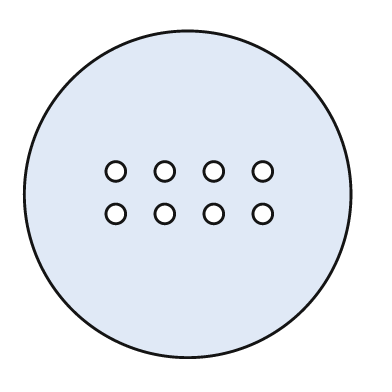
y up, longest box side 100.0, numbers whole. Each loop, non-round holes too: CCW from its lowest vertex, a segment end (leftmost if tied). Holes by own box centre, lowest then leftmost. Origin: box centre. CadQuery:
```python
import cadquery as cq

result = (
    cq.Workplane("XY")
    .moveTo(0.0, 0.0)
    .circle(50.0)
    .moveTo(-22.0, -6.0)
    .circle(3.0)
    .moveTo(-7.0, -6.0)
    .circle(3.0)
    .moveTo(8.0, -6.0)
    .circle(3.0)
    .moveTo(23.0, -6.0)
    .circle(3.0)
    .moveTo(-22.0, 7.0)
    .circle(3.0)
    .moveTo(-7.0, 7.0)
    .circle(3.0)
    .moveTo(8.0, 7.0)
    .circle(3.0)
    .moveTo(23.0, 7.0)
    .circle(3.0)
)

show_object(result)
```